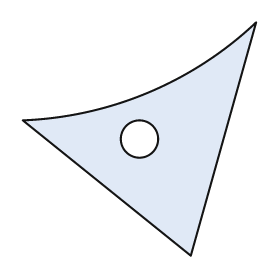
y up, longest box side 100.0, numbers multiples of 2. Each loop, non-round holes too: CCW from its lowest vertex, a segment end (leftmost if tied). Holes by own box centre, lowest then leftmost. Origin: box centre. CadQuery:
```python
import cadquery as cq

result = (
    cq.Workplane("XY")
    .moveTo(22.0, -50.0)
    .lineTo(50.0, 50.0)
    .threePointArc((4.0, 20.0), (-50.0, 8.0))
    .close()
    .moveTo(0.0, 0.0)
    .circle(8.0)
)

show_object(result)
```